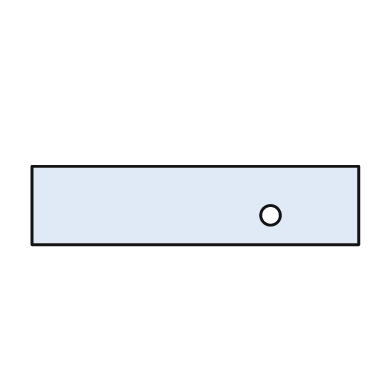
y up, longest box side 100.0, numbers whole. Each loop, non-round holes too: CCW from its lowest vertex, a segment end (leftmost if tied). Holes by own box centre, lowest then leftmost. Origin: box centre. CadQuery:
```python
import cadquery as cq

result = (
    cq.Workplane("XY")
    .moveTo(-50.0, -12.0)
    .lineTo(50.0, -12.0)
    .lineTo(50.0, 12.0)
    .lineTo(-50.0, 12.0)
    .close()
    .moveTo(23.0, -3.0)
    .circle(3.0)
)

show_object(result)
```